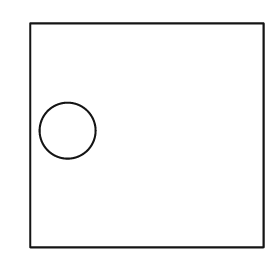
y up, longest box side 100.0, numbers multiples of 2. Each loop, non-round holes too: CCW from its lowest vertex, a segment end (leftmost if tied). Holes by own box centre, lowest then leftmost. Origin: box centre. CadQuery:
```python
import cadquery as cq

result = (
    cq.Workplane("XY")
    .moveTo(-50.0, -48.0)
    .lineTo(50.0, -48.0)
    .lineTo(50.0, 48.0)
    .lineTo(-50.0, 48.0)
    .close()
    .moveTo(-34.0, 2.0)
    .circle(12.0)
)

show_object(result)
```